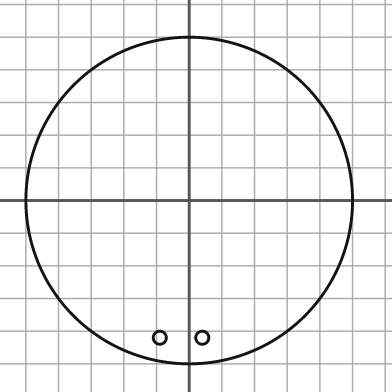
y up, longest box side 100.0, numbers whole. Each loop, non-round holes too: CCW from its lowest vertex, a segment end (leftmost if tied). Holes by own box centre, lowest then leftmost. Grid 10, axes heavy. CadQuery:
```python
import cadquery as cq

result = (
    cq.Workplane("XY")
    .moveTo(0.0, 0.0)
    .circle(50.0)
    .moveTo(-9.0, -42.0)
    .circle(2.0)
    .moveTo(4.0, -42.0)
    .circle(2.0)
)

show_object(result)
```